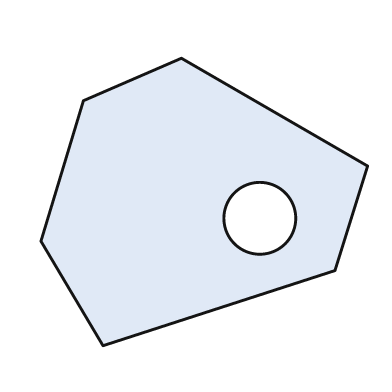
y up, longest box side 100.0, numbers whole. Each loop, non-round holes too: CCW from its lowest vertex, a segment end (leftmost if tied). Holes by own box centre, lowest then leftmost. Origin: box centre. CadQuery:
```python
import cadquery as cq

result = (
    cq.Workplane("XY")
    .moveTo(-31.0, -44.0)
    .lineTo(40.0, -21.0)
    .lineTo(50.0, 11.0)
    .lineTo(-7.0, 44.0)
    .lineTo(-37.0, 31.0)
    .lineTo(-50.0, -12.0)
    .close()
    .moveTo(17.0, -5.0)
    .circle(11.0)
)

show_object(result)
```